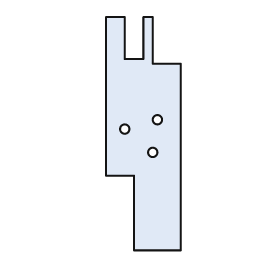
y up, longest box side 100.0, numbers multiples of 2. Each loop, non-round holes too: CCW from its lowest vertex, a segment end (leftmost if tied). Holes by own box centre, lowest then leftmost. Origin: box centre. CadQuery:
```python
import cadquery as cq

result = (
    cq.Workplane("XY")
    .moveTo(-4.0, -50.0)
    .lineTo(16.0, -50.0)
    .lineTo(16.0, 30.0)
    .lineTo(4.0, 30.0)
    .lineTo(4.0, 50.0)
    .lineTo(0.0, 50.0)
    .lineTo(0.0, 32.0)
    .lineTo(-8.0, 32.0)
    .lineTo(-8.0, 50.0)
    .lineTo(-16.0, 50.0)
    .lineTo(-16.0, -18.0)
    .lineTo(-4.0, -18.0)
    .close()
    .moveTo(4.0, -8.0)
    .circle(2.0)
    .moveTo(-8.0, 2.0)
    .circle(2.0)
    .moveTo(6.0, 6.0)
    .circle(2.0)
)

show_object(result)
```